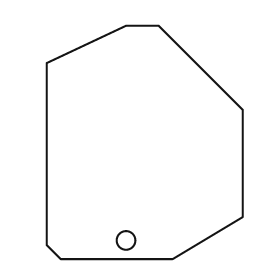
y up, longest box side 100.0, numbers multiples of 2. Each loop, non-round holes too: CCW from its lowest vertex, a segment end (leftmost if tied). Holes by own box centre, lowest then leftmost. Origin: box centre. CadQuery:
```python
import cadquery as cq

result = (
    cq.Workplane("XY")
    .moveTo(-36.0, -50.0)
    .lineTo(12.0, -50.0)
    .lineTo(42.0, -32.0)
    .lineTo(42.0, 14.0)
    .lineTo(6.0, 50.0)
    .lineTo(-8.0, 50.0)
    .lineTo(-42.0, 34.0)
    .lineTo(-42.0, -44.0)
    .close()
    .moveTo(-8.0, -42.0)
    .circle(4.0)
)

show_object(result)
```